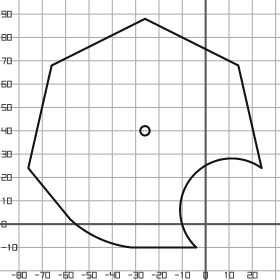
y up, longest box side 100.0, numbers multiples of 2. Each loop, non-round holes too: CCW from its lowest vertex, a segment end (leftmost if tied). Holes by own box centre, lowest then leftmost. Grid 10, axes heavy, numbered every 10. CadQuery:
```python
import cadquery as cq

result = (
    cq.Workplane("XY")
    .moveTo(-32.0, -10.0)
    .lineTo(-4.0, -10.0)
    .threePointArc((-6.0, 20.0), (24.0, 24.0))
    .lineTo(14.0, 68.0)
    .lineTo(-26.0, 88.0)
    .lineTo(-66.0, 68.0)
    .lineTo(-76.0, 24.0)
    .lineTo(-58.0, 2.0)
    .threePointArc((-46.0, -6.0), (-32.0, -10.0))
    .close()
    .moveTo(-26.0, 40.0)
    .circle(2.0)
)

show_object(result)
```